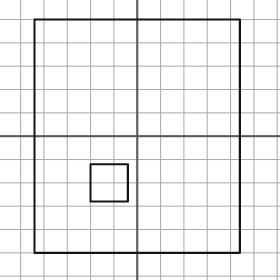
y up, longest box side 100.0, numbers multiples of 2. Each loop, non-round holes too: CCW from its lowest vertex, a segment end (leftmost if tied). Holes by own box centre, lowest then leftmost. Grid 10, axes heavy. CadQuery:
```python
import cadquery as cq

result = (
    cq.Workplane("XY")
    .moveTo(-44.0, -50.0)
    .lineTo(44.0, -50.0)
    .lineTo(44.0, 50.0)
    .lineTo(-44.0, 50.0)
    .close()
    .moveTo(-20.0, -28.0)
    .lineTo(-4.0, -28.0)
    .lineTo(-4.0, -12.0)
    .lineTo(-20.0, -12.0)
    .close()
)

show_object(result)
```